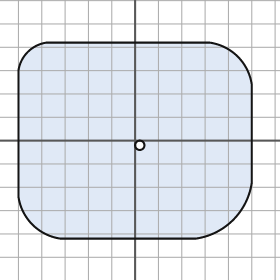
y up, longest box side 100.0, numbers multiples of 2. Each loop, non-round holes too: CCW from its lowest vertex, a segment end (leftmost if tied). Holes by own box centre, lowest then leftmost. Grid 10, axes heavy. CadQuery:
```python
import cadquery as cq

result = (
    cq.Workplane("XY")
    .moveTo(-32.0, -42.0)
    .lineTo(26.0, -42.0)
    .threePointArc((42.0, -34.0), (50.0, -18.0))
    .lineTo(50.0, 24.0)
    .threePointArc((44.0, 36.0), (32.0, 42.0))
    .lineTo(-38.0, 42.0)
    .threePointArc((-46.0, 38.0), (-50.0, 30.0))
    .lineTo(-50.0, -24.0)
    .threePointArc((-44.0, -36.0), (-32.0, -42.0))
    .close()
    .moveTo(2.0, -2.0)
    .circle(2.0)
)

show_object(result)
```